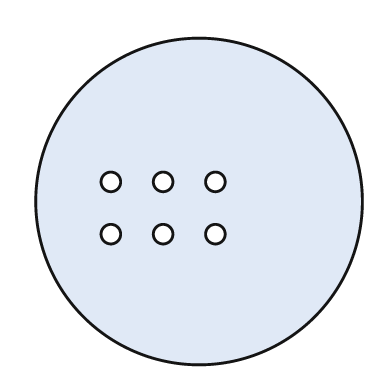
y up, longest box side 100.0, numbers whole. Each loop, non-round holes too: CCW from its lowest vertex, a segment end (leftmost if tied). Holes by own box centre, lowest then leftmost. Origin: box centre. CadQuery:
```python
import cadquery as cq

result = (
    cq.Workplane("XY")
    .moveTo(0.0, 0.0)
    .circle(50.0)
    .moveTo(-27.0, -10.0)
    .circle(3.0)
    .moveTo(-11.0, -10.0)
    .circle(3.0)
    .moveTo(5.0, -10.0)
    .circle(3.0)
    .moveTo(-27.0, 6.0)
    .circle(3.0)
    .moveTo(-11.0, 6.0)
    .circle(3.0)
    .moveTo(5.0, 6.0)
    .circle(3.0)
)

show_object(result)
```